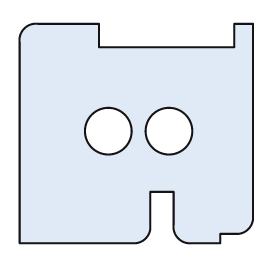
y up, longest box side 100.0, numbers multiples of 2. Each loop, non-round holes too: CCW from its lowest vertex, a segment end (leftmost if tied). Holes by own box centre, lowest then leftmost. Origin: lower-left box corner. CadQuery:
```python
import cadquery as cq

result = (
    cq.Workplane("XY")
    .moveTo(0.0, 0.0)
    .lineTo(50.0, 0.0)
    .threePointArc((54.0, 2.0), (56.0, 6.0))
    .lineTo(56.0, 22.0)
    .lineTo(66.0, 22.0)
    .lineTo(66.0, 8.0)
    .threePointArc((68.0, 2.0), (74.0, 0.0))
    .lineTo(86.0, 0.0)
    .lineTo(86.0, 4.0)
    .lineTo(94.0, 4.0)
    .threePointArc((98.0, 6.0), (100.0, 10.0))
    .lineTo(100.0, 94.0)
    .lineTo(92.0, 94.0)
    .lineTo(92.0, 84.0)
    .lineTo(34.0, 84.0)
    .lineTo(34.0, 94.0)
    .lineTo(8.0, 94.0)
    .threePointArc((2.0, 92.0), (0.0, 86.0))
    .close()
    .moveTo(38.0, 48.0)
    .circle(10.0)
    .moveTo(64.0, 48.0)
    .circle(10.0)
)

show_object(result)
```